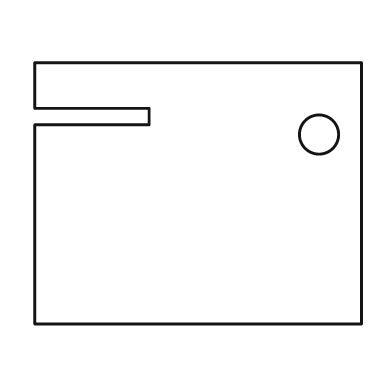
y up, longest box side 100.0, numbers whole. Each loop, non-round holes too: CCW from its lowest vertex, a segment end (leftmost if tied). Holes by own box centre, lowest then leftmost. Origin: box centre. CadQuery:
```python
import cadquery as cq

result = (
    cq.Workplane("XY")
    .moveTo(-50.0, -40.0)
    .lineTo(50.0, -40.0)
    .lineTo(50.0, 40.0)
    .lineTo(-50.0, 40.0)
    .lineTo(-50.0, 26.0)
    .lineTo(-15.0, 26.0)
    .lineTo(-15.0, 21.0)
    .lineTo(-50.0, 21.0)
    .close()
    .moveTo(37.0, 18.0)
    .circle(6.0)
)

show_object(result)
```